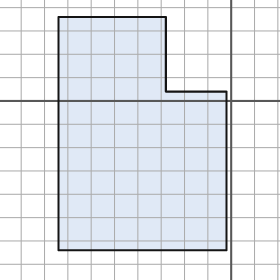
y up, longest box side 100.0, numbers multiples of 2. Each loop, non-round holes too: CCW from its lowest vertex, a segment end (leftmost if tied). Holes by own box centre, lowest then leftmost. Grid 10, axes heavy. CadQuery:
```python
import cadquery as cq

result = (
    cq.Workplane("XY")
    .moveTo(-74.0, -64.0)
    .lineTo(-2.0, -64.0)
    .lineTo(-2.0, 4.0)
    .lineTo(-28.0, 4.0)
    .lineTo(-28.0, 36.0)
    .lineTo(-74.0, 36.0)
    .close()
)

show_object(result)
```